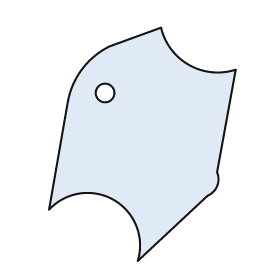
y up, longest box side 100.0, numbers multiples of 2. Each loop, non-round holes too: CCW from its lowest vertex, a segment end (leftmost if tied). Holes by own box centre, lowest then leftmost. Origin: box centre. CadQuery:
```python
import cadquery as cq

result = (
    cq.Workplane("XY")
    .moveTo(-2.0, -50.0)
    .lineTo(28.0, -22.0)
    .threePointArc((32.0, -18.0), (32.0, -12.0))
    .lineTo(40.0, 32.0)
    .threePointArc((20.0, 34.0), (8.0, 50.0))
    .lineTo(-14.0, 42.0)
    .threePointArc((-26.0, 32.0), (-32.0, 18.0))
    .lineTo(-40.0, -28.0)
    .threePointArc((-12.0, -24.0), (-2.0, -50.0))
    .close()
    .moveTo(-16.0, 22.0)
    .circle(4.0)
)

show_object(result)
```